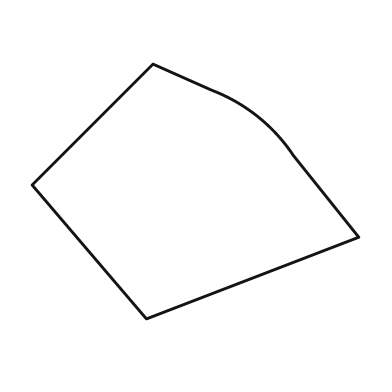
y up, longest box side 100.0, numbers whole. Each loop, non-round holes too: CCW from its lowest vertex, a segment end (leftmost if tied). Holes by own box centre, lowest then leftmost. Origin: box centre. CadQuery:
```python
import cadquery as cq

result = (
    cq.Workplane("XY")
    .moveTo(-15.0, -39.0)
    .lineTo(50.0, -14.0)
    .lineTo(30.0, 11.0)
    .threePointArc((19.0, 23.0), (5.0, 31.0))
    .lineTo(-13.0, 39.0)
    .lineTo(-50.0, 2.0)
    .close()
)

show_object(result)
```